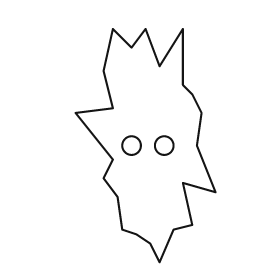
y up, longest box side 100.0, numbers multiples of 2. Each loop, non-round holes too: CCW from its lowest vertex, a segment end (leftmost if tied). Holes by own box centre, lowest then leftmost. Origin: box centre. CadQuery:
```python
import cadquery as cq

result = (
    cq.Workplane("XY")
    .moveTo(6.0, -50.0)
    .lineTo(12.0, -36.0)
    .lineTo(20.0, -34.0)
    .lineTo(16.0, -16.0)
    .lineTo(30.0, -20.0)
    .lineTo(22.0, 0.0)
    .lineTo(24.0, 14.0)
    .lineTo(20.0, 22.0)
    .lineTo(16.0, 26.0)
    .lineTo(16.0, 50.0)
    .lineTo(6.0, 34.0)
    .lineTo(0.0, 50.0)
    .lineTo(-6.0, 42.0)
    .lineTo(-14.0, 50.0)
    .lineTo(-18.0, 32.0)
    .lineTo(-14.0, 16.0)
    .lineTo(-30.0, 14.0)
    .lineTo(-14.0, -6.0)
    .lineTo(-18.0, -14.0)
    .lineTo(-12.0, -22.0)
    .lineTo(-10.0, -36.0)
    .lineTo(-4.0, -38.0)
    .lineTo(2.0, -42.0)
    .close()
    .moveTo(-6.0, 0.0)
    .circle(4.0)
    .moveTo(8.0, 0.0)
    .circle(4.0)
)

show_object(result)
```